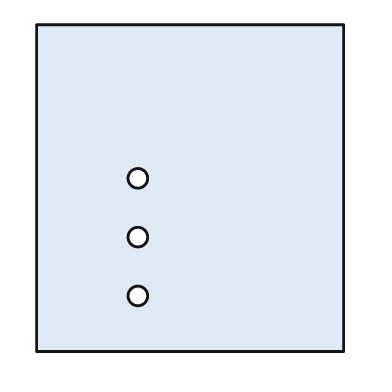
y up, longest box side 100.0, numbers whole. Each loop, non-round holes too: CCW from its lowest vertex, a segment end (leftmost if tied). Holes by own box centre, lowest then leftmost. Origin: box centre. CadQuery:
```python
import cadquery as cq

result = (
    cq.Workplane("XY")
    .moveTo(-47.0, -50.0)
    .lineTo(47.0, -50.0)
    .lineTo(47.0, 50.0)
    .lineTo(-47.0, 50.0)
    .close()
    .moveTo(-16.0, -33.0)
    .circle(3.0)
    .moveTo(-16.0, -15.0)
    .circle(3.0)
    .moveTo(-16.0, 3.0)
    .circle(3.0)
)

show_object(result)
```